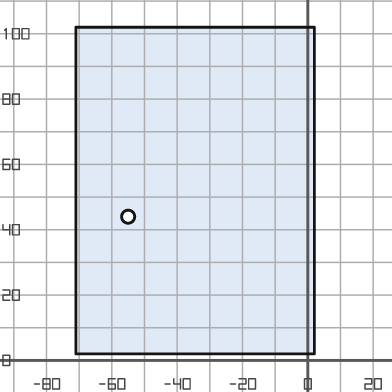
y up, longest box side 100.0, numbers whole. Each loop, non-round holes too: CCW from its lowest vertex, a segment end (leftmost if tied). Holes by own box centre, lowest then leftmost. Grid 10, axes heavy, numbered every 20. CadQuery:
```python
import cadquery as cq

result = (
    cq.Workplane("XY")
    .moveTo(-71.0, 2.0)
    .lineTo(2.0, 2.0)
    .lineTo(2.0, 102.0)
    .lineTo(-71.0, 102.0)
    .close()
    .moveTo(-55.0, 44.0)
    .circle(2.0)
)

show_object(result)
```